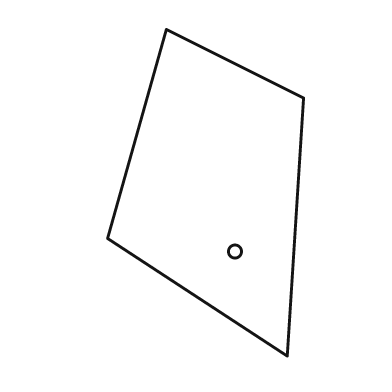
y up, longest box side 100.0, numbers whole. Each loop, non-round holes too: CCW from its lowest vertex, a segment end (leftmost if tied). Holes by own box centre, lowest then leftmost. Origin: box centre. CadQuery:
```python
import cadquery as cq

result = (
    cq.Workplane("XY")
    .moveTo(25.0, -50.0)
    .lineTo(30.0, 29.0)
    .lineTo(-12.0, 50.0)
    .lineTo(-30.0, -14.0)
    .close()
    .moveTo(9.0, -18.0)
    .circle(2.0)
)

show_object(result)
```